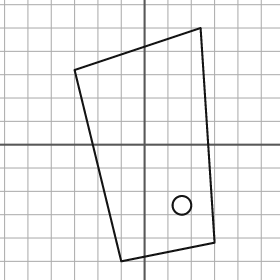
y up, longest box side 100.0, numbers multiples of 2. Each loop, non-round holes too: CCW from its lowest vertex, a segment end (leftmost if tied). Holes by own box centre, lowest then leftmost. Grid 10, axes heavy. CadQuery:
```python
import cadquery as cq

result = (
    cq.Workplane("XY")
    .moveTo(-10.0, -50.0)
    .lineTo(30.0, -42.0)
    .lineTo(24.0, 50.0)
    .lineTo(-30.0, 32.0)
    .close()
    .moveTo(16.0, -26.0)
    .circle(4.0)
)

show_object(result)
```